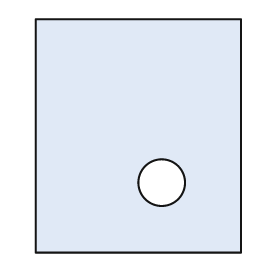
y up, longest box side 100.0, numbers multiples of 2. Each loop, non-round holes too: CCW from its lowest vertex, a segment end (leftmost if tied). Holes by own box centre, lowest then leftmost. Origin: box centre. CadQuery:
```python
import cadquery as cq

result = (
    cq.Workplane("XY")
    .moveTo(-44.0, -50.0)
    .lineTo(44.0, -50.0)
    .lineTo(44.0, 50.0)
    .lineTo(-44.0, 50.0)
    .close()
    .moveTo(10.0, -20.0)
    .circle(10.0)
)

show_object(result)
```